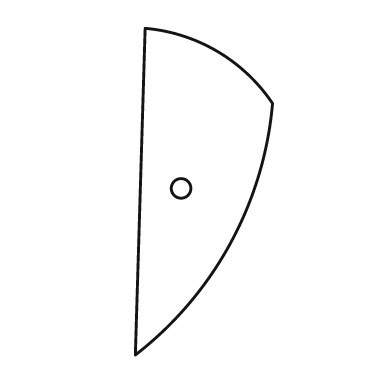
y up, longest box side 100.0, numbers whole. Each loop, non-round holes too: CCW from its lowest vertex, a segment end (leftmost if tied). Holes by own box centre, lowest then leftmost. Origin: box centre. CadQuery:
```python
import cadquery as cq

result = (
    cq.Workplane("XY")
    .moveTo(-21.0, -50.0)
    .threePointArc((8.0, -16.0), (21.0, 27.0))
    .threePointArc((4.0, 43.0), (-18.0, 50.0))
    .close()
    .moveTo(-7.0, 1.0)
    .circle(3.0)
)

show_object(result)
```